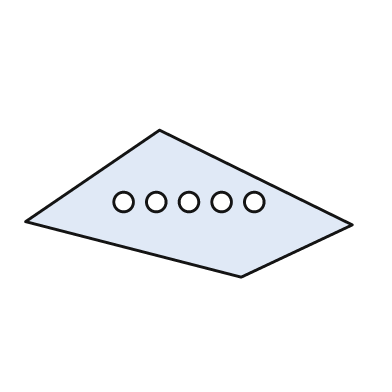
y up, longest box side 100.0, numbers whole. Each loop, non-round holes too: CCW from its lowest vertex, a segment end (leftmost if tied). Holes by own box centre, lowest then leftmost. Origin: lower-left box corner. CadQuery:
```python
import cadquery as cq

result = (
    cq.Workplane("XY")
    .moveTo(66.0, 0.0)
    .lineTo(100.0, 16.0)
    .lineTo(41.0, 45.0)
    .lineTo(0.0, 17.0)
    .close()
    .moveTo(30.0, 23.0)
    .circle(3.0)
    .moveTo(40.0, 23.0)
    .circle(3.0)
    .moveTo(50.0, 23.0)
    .circle(3.0)
    .moveTo(60.0, 23.0)
    .circle(3.0)
    .moveTo(70.0, 23.0)
    .circle(3.0)
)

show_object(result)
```